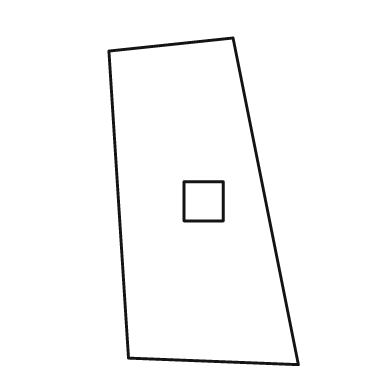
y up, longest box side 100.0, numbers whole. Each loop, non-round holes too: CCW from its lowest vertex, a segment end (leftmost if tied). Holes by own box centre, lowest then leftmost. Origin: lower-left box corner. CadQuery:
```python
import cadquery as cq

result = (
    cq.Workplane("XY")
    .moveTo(58.0, 0.0)
    .lineTo(38.0, 100.0)
    .lineTo(0.0, 96.0)
    .lineTo(6.0, 2.0)
    .close()
    .moveTo(23.0, 44.0)
    .lineTo(35.0, 44.0)
    .lineTo(35.0, 56.0)
    .lineTo(23.0, 56.0)
    .close()
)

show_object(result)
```